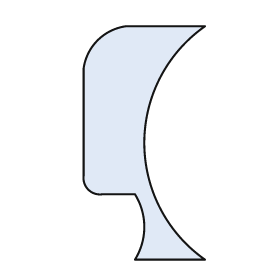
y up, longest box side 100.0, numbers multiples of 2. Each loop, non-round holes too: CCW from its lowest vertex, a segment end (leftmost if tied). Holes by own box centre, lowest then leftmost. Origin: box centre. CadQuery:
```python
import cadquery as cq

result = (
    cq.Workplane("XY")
    .moveTo(-4.0, -50.0)
    .lineTo(26.0, -50.0)
    .threePointArc((0.0, 0.0), (26.0, 50.0))
    .lineTo(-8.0, 50.0)
    .threePointArc((-20.0, 44.0), (-26.0, 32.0))
    .lineTo(-26.0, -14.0)
    .threePointArc((-24.0, -20.0), (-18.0, -22.0))
    .lineTo(-4.0, -22.0)
    .threePointArc((0.0, -36.0), (-4.0, -50.0))
    .close()
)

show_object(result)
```